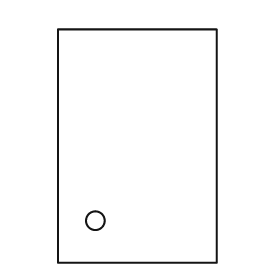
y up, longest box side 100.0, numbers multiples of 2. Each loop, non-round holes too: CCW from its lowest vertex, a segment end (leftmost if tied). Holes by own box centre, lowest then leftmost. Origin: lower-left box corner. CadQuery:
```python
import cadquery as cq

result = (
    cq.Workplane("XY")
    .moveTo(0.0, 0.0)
    .lineTo(68.0, 0.0)
    .lineTo(68.0, 100.0)
    .lineTo(0.0, 100.0)
    .close()
    .moveTo(16.0, 18.0)
    .circle(4.0)
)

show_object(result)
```